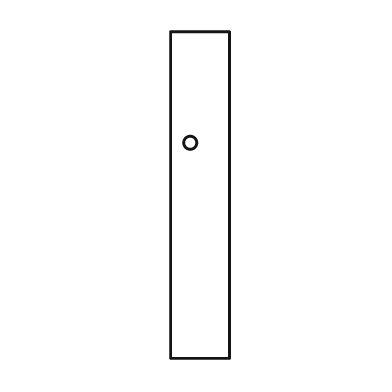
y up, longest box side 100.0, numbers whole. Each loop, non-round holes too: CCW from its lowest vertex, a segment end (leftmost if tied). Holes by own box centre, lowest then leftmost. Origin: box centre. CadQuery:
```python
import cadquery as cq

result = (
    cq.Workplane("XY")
    .moveTo(-9.0, -50.0)
    .lineTo(9.0, -50.0)
    .lineTo(9.0, 50.0)
    .lineTo(-9.0, 50.0)
    .close()
    .moveTo(-3.0, 16.0)
    .circle(2.0)
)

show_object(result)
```